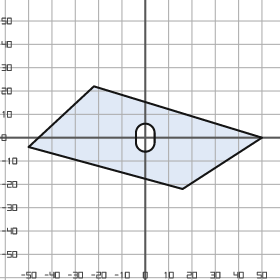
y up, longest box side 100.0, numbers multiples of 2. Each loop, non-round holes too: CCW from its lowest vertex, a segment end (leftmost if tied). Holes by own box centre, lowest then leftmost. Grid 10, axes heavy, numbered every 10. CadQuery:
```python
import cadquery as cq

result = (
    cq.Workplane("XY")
    .moveTo(16.0, -22.0)
    .lineTo(50.0, 0.0)
    .lineTo(-22.0, 22.0)
    .lineTo(-50.0, -4.0)
    .close()
    .moveTo(-4.0, -2.0)
    .threePointArc((0.0, -6.0), (4.0, -2.0))
    .lineTo(4.0, 2.0)
    .threePointArc((0.0, 6.0), (-4.0, 2.0))
    .close()
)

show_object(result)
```